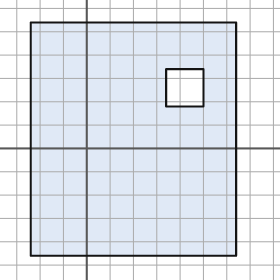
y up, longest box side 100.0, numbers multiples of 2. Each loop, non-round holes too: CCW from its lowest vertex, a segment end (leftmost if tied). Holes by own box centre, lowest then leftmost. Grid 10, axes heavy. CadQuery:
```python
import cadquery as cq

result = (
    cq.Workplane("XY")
    .moveTo(-24.0, -46.0)
    .lineTo(64.0, -46.0)
    .lineTo(64.0, 54.0)
    .lineTo(-24.0, 54.0)
    .close()
    .moveTo(34.0, 18.0)
    .lineTo(50.0, 18.0)
    .lineTo(50.0, 34.0)
    .lineTo(34.0, 34.0)
    .close()
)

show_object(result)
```